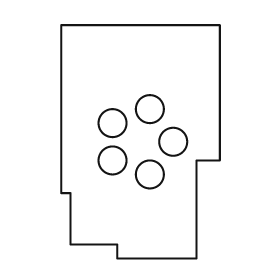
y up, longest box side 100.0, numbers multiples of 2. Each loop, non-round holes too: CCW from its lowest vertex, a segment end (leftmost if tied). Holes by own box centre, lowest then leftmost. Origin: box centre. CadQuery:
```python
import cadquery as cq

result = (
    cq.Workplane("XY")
    .moveTo(-10.0, -50.0)
    .lineTo(24.0, -50.0)
    .lineTo(24.0, -8.0)
    .lineTo(34.0, -8.0)
    .lineTo(34.0, 50.0)
    .lineTo(-34.0, 50.0)
    .lineTo(-34.0, -22.0)
    .lineTo(-30.0, -22.0)
    .lineTo(-30.0, -44.0)
    .lineTo(-10.0, -44.0)
    .close()
    .moveTo(4.0, -14.0)
    .circle(6.0)
    .moveTo(-12.0, -8.0)
    .circle(6.0)
    .moveTo(14.0, 0.0)
    .circle(6.0)
    .moveTo(-12.0, 8.0)
    .circle(6.0)
    .moveTo(4.0, 14.0)
    .circle(6.0)
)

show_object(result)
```